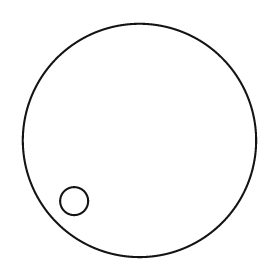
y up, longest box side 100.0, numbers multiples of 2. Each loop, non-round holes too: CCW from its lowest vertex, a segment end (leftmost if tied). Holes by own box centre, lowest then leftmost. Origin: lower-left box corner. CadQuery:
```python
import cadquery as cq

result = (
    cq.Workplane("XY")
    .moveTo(50.0, 50.0)
    .circle(50.0)
    .moveTo(22.0, 24.0)
    .circle(6.0)
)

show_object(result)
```